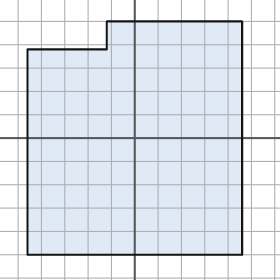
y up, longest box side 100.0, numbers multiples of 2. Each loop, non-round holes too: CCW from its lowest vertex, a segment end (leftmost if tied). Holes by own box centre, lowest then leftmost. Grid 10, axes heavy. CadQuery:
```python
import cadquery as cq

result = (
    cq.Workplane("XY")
    .moveTo(-46.0, -50.0)
    .lineTo(46.0, -50.0)
    .lineTo(46.0, 50.0)
    .lineTo(-12.0, 50.0)
    .lineTo(-12.0, 38.0)
    .lineTo(-46.0, 38.0)
    .close()
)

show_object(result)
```